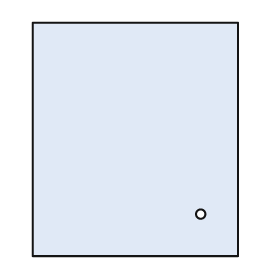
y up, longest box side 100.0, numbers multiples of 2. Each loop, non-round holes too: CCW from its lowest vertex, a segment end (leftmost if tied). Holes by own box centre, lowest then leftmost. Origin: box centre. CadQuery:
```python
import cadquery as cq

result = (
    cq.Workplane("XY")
    .moveTo(-44.0, -50.0)
    .lineTo(44.0, -50.0)
    .lineTo(44.0, 50.0)
    .lineTo(-44.0, 50.0)
    .close()
    .moveTo(28.0, -32.0)
    .circle(2.0)
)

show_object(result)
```